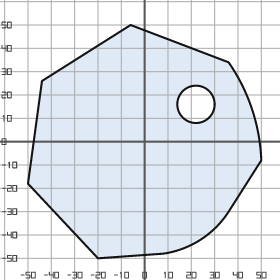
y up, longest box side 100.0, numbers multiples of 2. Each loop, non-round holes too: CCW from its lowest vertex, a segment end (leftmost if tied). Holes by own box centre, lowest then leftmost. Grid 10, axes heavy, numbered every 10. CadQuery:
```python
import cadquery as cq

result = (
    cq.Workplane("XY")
    .moveTo(-20.0, -50.0)
    .lineTo(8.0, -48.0)
    .threePointArc((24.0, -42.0), (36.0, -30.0))
    .lineTo(50.0, -8.0)
    .threePointArc((46.0, 14.0), (36.0, 34.0))
    .lineTo(-6.0, 50.0)
    .lineTo(-44.0, 26.0)
    .lineTo(-50.0, -18.0)
    .close()
    .moveTo(22.0, 16.0)
    .circle(8.0)
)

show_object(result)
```